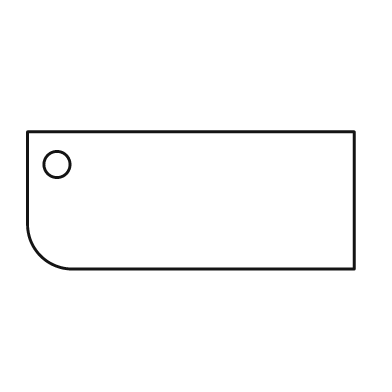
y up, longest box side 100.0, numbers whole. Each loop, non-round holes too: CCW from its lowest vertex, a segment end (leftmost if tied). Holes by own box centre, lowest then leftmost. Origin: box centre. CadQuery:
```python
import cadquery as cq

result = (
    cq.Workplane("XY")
    .moveTo(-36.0, -21.0)
    .lineTo(50.0, -21.0)
    .lineTo(50.0, 21.0)
    .lineTo(-50.0, 21.0)
    .lineTo(-50.0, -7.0)
    .threePointArc((-46.0, -17.0), (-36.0, -21.0))
    .close()
    .moveTo(-41.0, 11.0)
    .circle(4.0)
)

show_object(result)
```